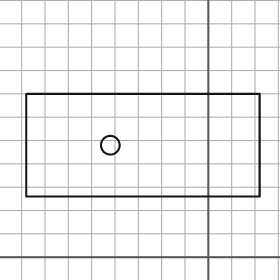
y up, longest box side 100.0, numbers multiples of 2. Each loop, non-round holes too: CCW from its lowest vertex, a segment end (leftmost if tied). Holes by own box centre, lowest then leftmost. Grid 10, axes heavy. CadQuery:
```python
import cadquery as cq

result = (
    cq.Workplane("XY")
    .moveTo(-78.0, 26.0)
    .lineTo(22.0, 26.0)
    .lineTo(22.0, 70.0)
    .lineTo(-78.0, 70.0)
    .close()
    .moveTo(-42.0, 48.0)
    .circle(4.0)
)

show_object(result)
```